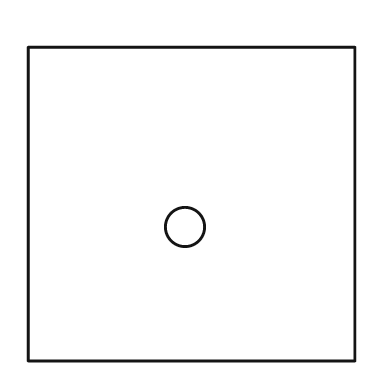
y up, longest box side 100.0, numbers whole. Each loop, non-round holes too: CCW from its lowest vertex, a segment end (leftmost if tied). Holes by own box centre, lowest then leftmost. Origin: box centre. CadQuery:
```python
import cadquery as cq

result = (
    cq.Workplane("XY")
    .moveTo(-50.0, -48.0)
    .lineTo(50.0, -48.0)
    .lineTo(50.0, 48.0)
    .lineTo(-50.0, 48.0)
    .close()
    .moveTo(-2.0, -7.0)
    .circle(6.0)
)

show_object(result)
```